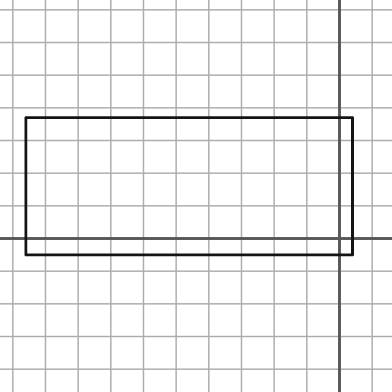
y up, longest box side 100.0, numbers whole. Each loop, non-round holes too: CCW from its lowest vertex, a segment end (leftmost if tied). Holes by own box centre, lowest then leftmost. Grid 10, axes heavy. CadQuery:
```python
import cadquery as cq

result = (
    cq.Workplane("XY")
    .moveTo(-96.0, -5.0)
    .lineTo(4.0, -5.0)
    .lineTo(4.0, 37.0)
    .lineTo(-96.0, 37.0)
    .close()
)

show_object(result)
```